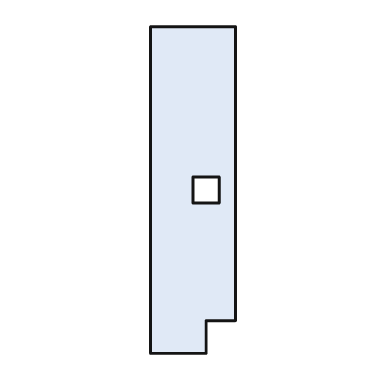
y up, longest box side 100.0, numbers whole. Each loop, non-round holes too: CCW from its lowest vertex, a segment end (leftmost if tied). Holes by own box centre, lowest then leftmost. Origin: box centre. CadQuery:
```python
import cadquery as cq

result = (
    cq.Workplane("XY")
    .moveTo(-13.0, -50.0)
    .lineTo(4.0, -50.0)
    .lineTo(4.0, -40.0)
    .lineTo(13.0, -40.0)
    .lineTo(13.0, 50.0)
    .lineTo(-13.0, 50.0)
    .close()
    .moveTo(0.0, -4.0)
    .lineTo(8.0, -4.0)
    .lineTo(8.0, 4.0)
    .lineTo(0.0, 4.0)
    .close()
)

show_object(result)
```